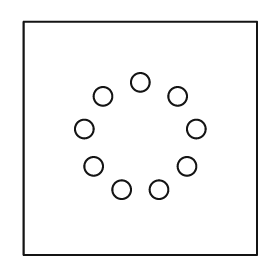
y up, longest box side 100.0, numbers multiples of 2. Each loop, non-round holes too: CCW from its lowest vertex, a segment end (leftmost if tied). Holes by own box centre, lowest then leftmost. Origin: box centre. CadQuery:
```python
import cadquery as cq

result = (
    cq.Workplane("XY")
    .moveTo(-50.0, -50.0)
    .lineTo(50.0, -50.0)
    .lineTo(50.0, 50.0)
    .lineTo(-50.0, 50.0)
    .close()
    .moveTo(-8.0, -22.0)
    .circle(4.0)
    .moveTo(8.0, -22.0)
    .circle(4.0)
    .moveTo(-20.0, -12.0)
    .circle(4.0)
    .moveTo(20.0, -12.0)
    .circle(4.0)
    .moveTo(-24.0, 4.0)
    .circle(4.0)
    .moveTo(24.0, 4.0)
    .circle(4.0)
    .moveTo(-16.0, 18.0)
    .circle(4.0)
    .moveTo(16.0, 18.0)
    .circle(4.0)
    .moveTo(0.0, 24.0)
    .circle(4.0)
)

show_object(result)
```